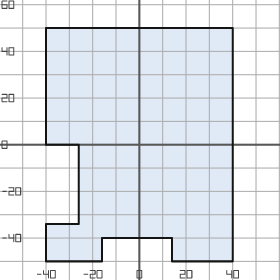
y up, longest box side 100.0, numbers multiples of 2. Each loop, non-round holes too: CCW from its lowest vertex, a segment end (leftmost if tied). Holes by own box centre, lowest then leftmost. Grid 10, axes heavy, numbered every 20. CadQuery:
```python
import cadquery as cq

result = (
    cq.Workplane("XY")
    .moveTo(-40.0, -50.0)
    .lineTo(-16.0, -50.0)
    .lineTo(-16.0, -40.0)
    .lineTo(14.0, -40.0)
    .lineTo(14.0, -50.0)
    .lineTo(40.0, -50.0)
    .lineTo(40.0, 50.0)
    .lineTo(-40.0, 50.0)
    .lineTo(-40.0, 0.0)
    .lineTo(-26.0, 0.0)
    .lineTo(-26.0, -34.0)
    .lineTo(-40.0, -34.0)
    .close()
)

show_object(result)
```